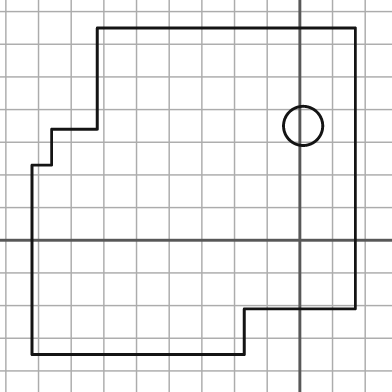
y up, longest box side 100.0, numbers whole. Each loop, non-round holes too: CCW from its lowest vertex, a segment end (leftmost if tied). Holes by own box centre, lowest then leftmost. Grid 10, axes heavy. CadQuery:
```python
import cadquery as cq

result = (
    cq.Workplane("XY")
    .moveTo(-82.0, -35.0)
    .lineTo(-17.0, -35.0)
    .lineTo(-17.0, -21.0)
    .lineTo(17.0, -21.0)
    .lineTo(17.0, 65.0)
    .lineTo(-62.0, 65.0)
    .lineTo(-62.0, 34.0)
    .lineTo(-76.0, 34.0)
    .lineTo(-76.0, 23.0)
    .lineTo(-82.0, 23.0)
    .close()
    .moveTo(1.0, 35.0)
    .circle(6.0)
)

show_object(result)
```